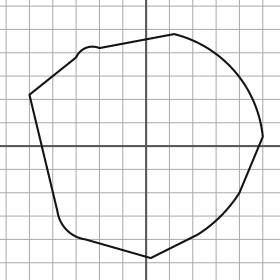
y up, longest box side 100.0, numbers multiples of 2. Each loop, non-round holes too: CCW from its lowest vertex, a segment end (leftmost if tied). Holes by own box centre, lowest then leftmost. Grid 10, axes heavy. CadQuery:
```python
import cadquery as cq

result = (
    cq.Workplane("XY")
    .moveTo(2.0, -48.0)
    .lineTo(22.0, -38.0)
    .threePointArc((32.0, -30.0), (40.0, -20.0))
    .lineTo(50.0, 4.0)
    .threePointArc((38.0, 32.0), (12.0, 48.0))
    .lineTo(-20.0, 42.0)
    .threePointArc((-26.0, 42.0), (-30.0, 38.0))
    .lineTo(-50.0, 22.0)
    .lineTo(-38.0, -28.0)
    .threePointArc((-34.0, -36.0), (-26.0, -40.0))
    .close()
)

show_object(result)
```